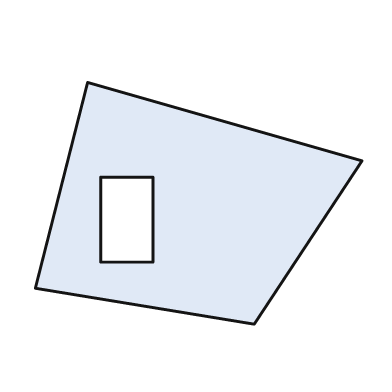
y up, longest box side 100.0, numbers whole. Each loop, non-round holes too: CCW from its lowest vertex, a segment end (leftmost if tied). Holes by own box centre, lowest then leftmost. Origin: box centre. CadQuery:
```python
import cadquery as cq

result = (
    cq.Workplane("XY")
    .moveTo(17.0, -37.0)
    .lineTo(50.0, 13.0)
    .lineTo(-34.0, 37.0)
    .lineTo(-50.0, -26.0)
    .close()
    .moveTo(-30.0, -18.0)
    .lineTo(-14.0, -18.0)
    .lineTo(-14.0, 8.0)
    .lineTo(-30.0, 8.0)
    .close()
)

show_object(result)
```